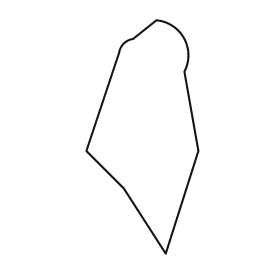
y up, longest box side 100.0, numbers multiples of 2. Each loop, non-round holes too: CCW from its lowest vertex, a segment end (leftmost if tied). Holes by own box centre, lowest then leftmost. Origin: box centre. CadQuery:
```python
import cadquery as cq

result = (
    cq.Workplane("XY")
    .moveTo(10.0, -50.0)
    .lineTo(24.0, -6.0)
    .lineTo(18.0, 28.0)
    .threePointArc((18.0, 42.0), (6.0, 50.0))
    .lineTo(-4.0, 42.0)
    .threePointArc((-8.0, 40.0), (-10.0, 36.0))
    .lineTo(-24.0, -6.0)
    .lineTo(-8.0, -22.0)
    .close()
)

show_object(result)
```